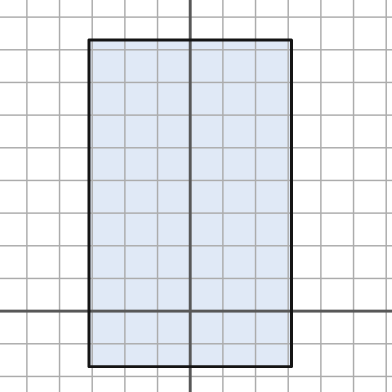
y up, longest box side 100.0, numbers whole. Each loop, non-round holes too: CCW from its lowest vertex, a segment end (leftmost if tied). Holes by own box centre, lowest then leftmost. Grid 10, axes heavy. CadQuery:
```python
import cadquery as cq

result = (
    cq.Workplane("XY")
    .moveTo(-31.0, -17.0)
    .lineTo(31.0, -17.0)
    .lineTo(31.0, 83.0)
    .lineTo(-31.0, 83.0)
    .close()
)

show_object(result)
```